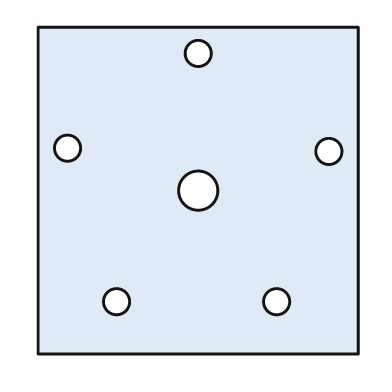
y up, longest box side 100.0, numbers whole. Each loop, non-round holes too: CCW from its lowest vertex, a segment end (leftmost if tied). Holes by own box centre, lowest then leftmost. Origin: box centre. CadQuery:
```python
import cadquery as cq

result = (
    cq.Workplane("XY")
    .moveTo(-49.0, -50.0)
    .lineTo(49.0, -50.0)
    .lineTo(49.0, 50.0)
    .lineTo(-49.0, 50.0)
    .close()
    .moveTo(-25.0, -34.0)
    .circle(4.0)
    .moveTo(24.0, -34.0)
    .circle(4.0)
    .moveTo(0.0, 0.0)
    .circle(6.0)
    .moveTo(40.0, 12.0)
    .circle(4.0)
    .moveTo(-40.0, 13.0)
    .circle(4.0)
    .moveTo(0.0, 42.0)
    .circle(4.0)
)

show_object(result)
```